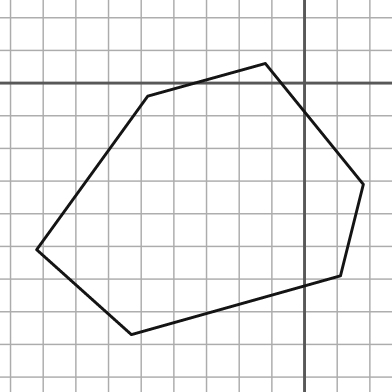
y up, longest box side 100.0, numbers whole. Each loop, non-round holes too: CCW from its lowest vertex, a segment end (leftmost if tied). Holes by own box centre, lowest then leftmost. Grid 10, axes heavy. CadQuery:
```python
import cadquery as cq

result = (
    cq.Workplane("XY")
    .moveTo(-53.0, -77.0)
    .lineTo(11.0, -59.0)
    .lineTo(18.0, -31.0)
    .lineTo(-12.0, 6.0)
    .lineTo(-48.0, -4.0)
    .lineTo(-82.0, -51.0)
    .close()
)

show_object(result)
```